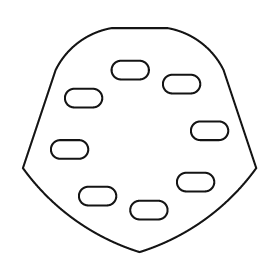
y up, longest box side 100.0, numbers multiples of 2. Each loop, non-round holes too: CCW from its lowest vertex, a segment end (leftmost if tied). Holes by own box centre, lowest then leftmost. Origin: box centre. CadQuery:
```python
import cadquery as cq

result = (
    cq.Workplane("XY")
    .moveTo(0.0, -48.0)
    .threePointArc((28.0, -34.0), (50.0, -12.0))
    .lineTo(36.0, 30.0)
    .threePointArc((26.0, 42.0), (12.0, 48.0))
    .lineTo(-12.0, 48.0)
    .threePointArc((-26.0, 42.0), (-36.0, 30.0))
    .lineTo(-50.0, -12.0)
    .threePointArc((-28.0, -34.0), (0.0, -48.0))
    .close()
    .moveTo(0.0, -34.0)
    .lineTo(8.0, -34.0)
    .threePointArc((12.0, -30.0), (8.0, -26.0))
    .lineTo(0.0, -26.0)
    .threePointArc((-4.0, -30.0), (0.0, -34.0))
    .close()
    .moveTo(-22.0, -28.0)
    .lineTo(-14.0, -28.0)
    .threePointArc((-10.0, -24.0), (-14.0, -20.0))
    .lineTo(-22.0, -20.0)
    .threePointArc((-26.0, -24.0), (-22.0, -28.0))
    .close()
    .moveTo(20.0, -22.0)
    .lineTo(28.0, -22.0)
    .threePointArc((32.0, -18.0), (28.0, -14.0))
    .lineTo(20.0, -14.0)
    .threePointArc((16.0, -18.0), (20.0, -22.0))
    .close()
    .moveTo(-34.0, -8.0)
    .lineTo(-26.0, -8.0)
    .threePointArc((-22.0, -4.0), (-26.0, 0.0))
    .lineTo(-34.0, 0.0)
    .threePointArc((-38.0, -4.0), (-34.0, -8.0))
    .close()
    .moveTo(26.0, 0.0)
    .lineTo(34.0, 0.0)
    .threePointArc((38.0, 4.0), (34.0, 8.0))
    .lineTo(26.0, 8.0)
    .threePointArc((22.0, 4.0), (26.0, 0.0))
    .close()
    .moveTo(-28.0, 14.0)
    .lineTo(-20.0, 14.0)
    .threePointArc((-16.0, 18.0), (-20.0, 22.0))
    .lineTo(-28.0, 22.0)
    .threePointArc((-32.0, 18.0), (-28.0, 14.0))
    .close()
    .moveTo(14.0, 20.0)
    .lineTo(22.0, 20.0)
    .threePointArc((26.0, 24.0), (22.0, 28.0))
    .lineTo(14.0, 28.0)
    .threePointArc((10.0, 24.0), (14.0, 20.0))
    .close()
    .moveTo(-8.0, 26.0)
    .lineTo(0.0, 26.0)
    .threePointArc((4.0, 30.0), (0.0, 34.0))
    .lineTo(-8.0, 34.0)
    .threePointArc((-12.0, 30.0), (-8.0, 26.0))
    .close()
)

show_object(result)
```